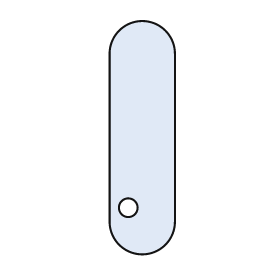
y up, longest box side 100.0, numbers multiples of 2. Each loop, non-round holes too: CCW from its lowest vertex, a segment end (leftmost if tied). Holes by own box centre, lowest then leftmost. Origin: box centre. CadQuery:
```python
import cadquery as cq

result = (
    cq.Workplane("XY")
    .moveTo(-14.0, -36.0)
    .threePointArc((0.0, -50.0), (14.0, -36.0))
    .lineTo(14.0, 36.0)
    .threePointArc((0.0, 50.0), (-14.0, 36.0))
    .close()
    .moveTo(-6.0, -30.0)
    .circle(4.0)
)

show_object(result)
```